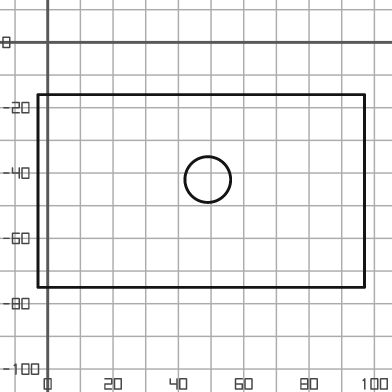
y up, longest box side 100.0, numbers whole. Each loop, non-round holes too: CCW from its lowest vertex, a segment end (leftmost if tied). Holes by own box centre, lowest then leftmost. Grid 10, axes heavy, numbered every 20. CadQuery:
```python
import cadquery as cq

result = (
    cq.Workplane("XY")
    .moveTo(-3.0, -75.0)
    .lineTo(97.0, -75.0)
    .lineTo(97.0, -16.0)
    .lineTo(-3.0, -16.0)
    .close()
    .moveTo(49.0, -42.0)
    .circle(7.0)
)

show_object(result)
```